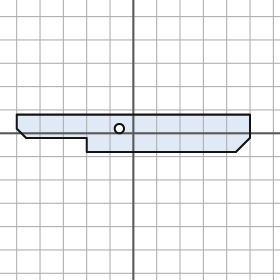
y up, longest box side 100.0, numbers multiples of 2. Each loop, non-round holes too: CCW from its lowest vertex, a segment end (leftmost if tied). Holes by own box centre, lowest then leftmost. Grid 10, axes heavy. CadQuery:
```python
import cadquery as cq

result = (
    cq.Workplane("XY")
    .moveTo(-20.0, -8.0)
    .lineTo(44.0, -8.0)
    .lineTo(50.0, -2.0)
    .lineTo(50.0, 8.0)
    .lineTo(-50.0, 8.0)
    .lineTo(-50.0, 2.0)
    .lineTo(-46.0, -2.0)
    .lineTo(-20.0, -2.0)
    .close()
    .moveTo(-6.0, 2.0)
    .circle(2.0)
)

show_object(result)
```